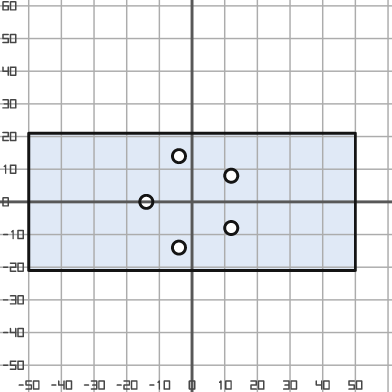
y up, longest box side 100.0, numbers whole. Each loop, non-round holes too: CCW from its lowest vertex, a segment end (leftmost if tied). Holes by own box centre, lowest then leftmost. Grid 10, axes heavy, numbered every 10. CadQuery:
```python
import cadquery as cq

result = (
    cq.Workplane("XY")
    .moveTo(-50.0, -21.0)
    .lineTo(50.0, -21.0)
    .lineTo(50.0, 21.0)
    .lineTo(-50.0, 21.0)
    .close()
    .moveTo(-4.0, -14.0)
    .circle(2.0)
    .moveTo(12.0, -8.0)
    .circle(2.0)
    .moveTo(-14.0, 0.0)
    .circle(2.0)
    .moveTo(12.0, 8.0)
    .circle(2.0)
    .moveTo(-4.0, 14.0)
    .circle(2.0)
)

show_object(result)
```